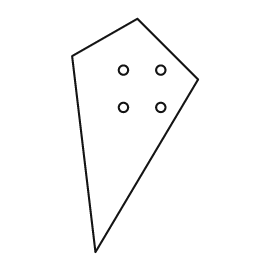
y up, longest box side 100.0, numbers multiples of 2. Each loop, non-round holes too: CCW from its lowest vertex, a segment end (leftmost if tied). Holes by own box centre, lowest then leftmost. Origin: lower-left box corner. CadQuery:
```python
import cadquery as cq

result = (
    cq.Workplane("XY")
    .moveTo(10.0, 0.0)
    .lineTo(54.0, 74.0)
    .lineTo(28.0, 100.0)
    .lineTo(0.0, 84.0)
    .close()
    .moveTo(22.0, 62.0)
    .circle(2.0)
    .moveTo(38.0, 62.0)
    .circle(2.0)
    .moveTo(22.0, 78.0)
    .circle(2.0)
    .moveTo(38.0, 78.0)
    .circle(2.0)
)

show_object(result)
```